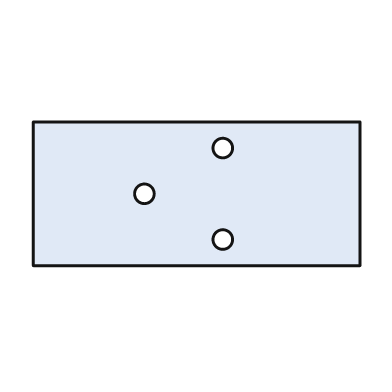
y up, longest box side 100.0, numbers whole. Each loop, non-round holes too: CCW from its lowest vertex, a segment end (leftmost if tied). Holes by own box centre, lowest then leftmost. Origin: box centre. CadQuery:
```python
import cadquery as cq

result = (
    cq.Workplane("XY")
    .moveTo(-50.0, -22.0)
    .lineTo(50.0, -22.0)
    .lineTo(50.0, 22.0)
    .lineTo(-50.0, 22.0)
    .close()
    .moveTo(8.0, -14.0)
    .circle(3.0)
    .moveTo(-16.0, 0.0)
    .circle(3.0)
    .moveTo(8.0, 14.0)
    .circle(3.0)
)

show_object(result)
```